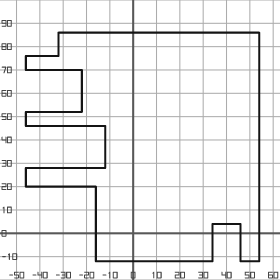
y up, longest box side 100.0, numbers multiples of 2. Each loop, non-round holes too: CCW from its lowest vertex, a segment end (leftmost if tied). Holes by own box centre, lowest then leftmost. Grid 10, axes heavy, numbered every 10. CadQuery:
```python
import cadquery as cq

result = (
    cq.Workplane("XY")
    .moveTo(-16.0, -12.0)
    .lineTo(34.0, -12.0)
    .lineTo(34.0, 4.0)
    .lineTo(46.0, 4.0)
    .lineTo(46.0, -12.0)
    .lineTo(54.0, -12.0)
    .lineTo(54.0, 86.0)
    .lineTo(-32.0, 86.0)
    .lineTo(-32.0, 76.0)
    .lineTo(-46.0, 76.0)
    .lineTo(-46.0, 70.0)
    .lineTo(-22.0, 70.0)
    .lineTo(-22.0, 52.0)
    .lineTo(-46.0, 52.0)
    .lineTo(-46.0, 46.0)
    .lineTo(-12.0, 46.0)
    .lineTo(-12.0, 28.0)
    .lineTo(-46.0, 28.0)
    .lineTo(-46.0, 20.0)
    .lineTo(-16.0, 20.0)
    .close()
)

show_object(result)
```